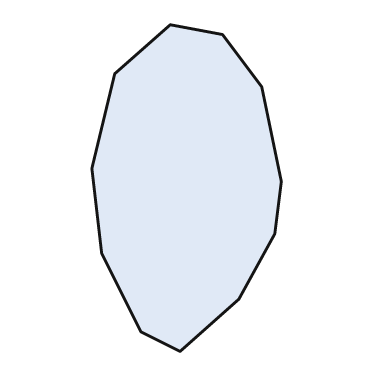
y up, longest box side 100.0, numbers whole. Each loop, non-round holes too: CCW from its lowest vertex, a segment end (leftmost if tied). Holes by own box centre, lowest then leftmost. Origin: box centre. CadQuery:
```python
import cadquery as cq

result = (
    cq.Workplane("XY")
    .moveTo(-2.0, -50.0)
    .lineTo(16.0, -34.0)
    .lineTo(27.0, -14.0)
    .lineTo(29.0, 2.0)
    .lineTo(23.0, 31.0)
    .lineTo(11.0, 47.0)
    .lineTo(-5.0, 50.0)
    .lineTo(-22.0, 35.0)
    .lineTo(-29.0, 6.0)
    .lineTo(-26.0, -20.0)
    .lineTo(-14.0, -44.0)
    .close()
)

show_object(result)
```